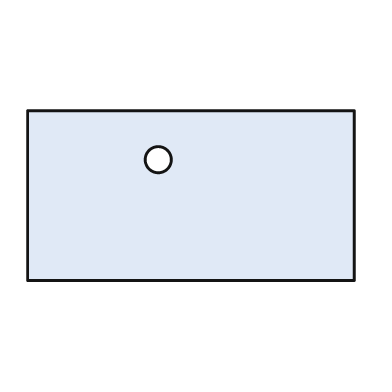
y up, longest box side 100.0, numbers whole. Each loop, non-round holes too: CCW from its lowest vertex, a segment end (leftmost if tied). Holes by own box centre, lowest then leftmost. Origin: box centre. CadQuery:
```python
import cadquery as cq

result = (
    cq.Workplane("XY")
    .moveTo(-50.0, -26.0)
    .lineTo(50.0, -26.0)
    .lineTo(50.0, 26.0)
    .lineTo(-50.0, 26.0)
    .close()
    .moveTo(-10.0, 11.0)
    .circle(4.0)
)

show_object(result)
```